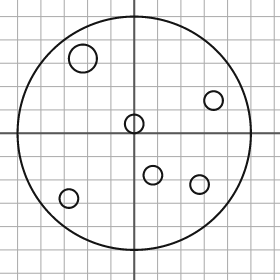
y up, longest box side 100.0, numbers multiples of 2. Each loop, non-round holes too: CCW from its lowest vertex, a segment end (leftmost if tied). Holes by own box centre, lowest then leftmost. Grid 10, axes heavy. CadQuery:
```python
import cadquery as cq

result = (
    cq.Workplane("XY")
    .moveTo(0.0, 0.0)
    .circle(50.0)
    .moveTo(-28.0, -28.0)
    .circle(4.0)
    .moveTo(28.0, -22.0)
    .circle(4.0)
    .moveTo(8.0, -18.0)
    .circle(4.0)
    .moveTo(0.0, 4.0)
    .circle(4.0)
    .moveTo(34.0, 14.0)
    .circle(4.0)
    .moveTo(-22.0, 32.0)
    .circle(6.0)
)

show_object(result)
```